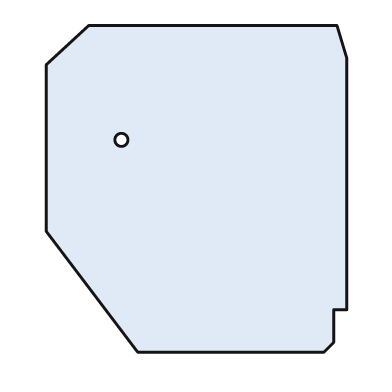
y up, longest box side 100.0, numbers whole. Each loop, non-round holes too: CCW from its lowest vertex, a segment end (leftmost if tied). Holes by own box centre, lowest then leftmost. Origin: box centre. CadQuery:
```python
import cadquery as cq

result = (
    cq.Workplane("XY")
    .moveTo(-18.0, -50.0)
    .lineTo(39.0, -50.0)
    .lineTo(42.0, -47.0)
    .lineTo(42.0, -37.0)
    .lineTo(46.0, -37.0)
    .lineTo(46.0, 40.0)
    .lineTo(43.0, 50.0)
    .lineTo(-33.0, 50.0)
    .lineTo(-46.0, 38.0)
    .lineTo(-46.0, -13.0)
    .close()
    .moveTo(-23.0, 15.0)
    .circle(2.0)
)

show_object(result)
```